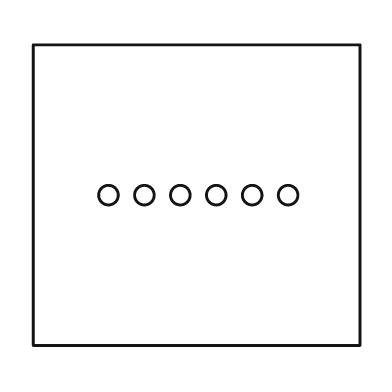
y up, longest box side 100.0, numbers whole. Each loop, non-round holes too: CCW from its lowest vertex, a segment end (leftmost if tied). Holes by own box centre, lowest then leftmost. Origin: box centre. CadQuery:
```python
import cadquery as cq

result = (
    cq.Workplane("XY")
    .moveTo(-50.0, -46.0)
    .lineTo(50.0, -46.0)
    .lineTo(50.0, 46.0)
    .lineTo(-50.0, 46.0)
    .close()
    .moveTo(-27.0, 0.0)
    .circle(3.0)
    .moveTo(-16.0, 0.0)
    .circle(3.0)
    .moveTo(-5.0, 0.0)
    .circle(3.0)
    .moveTo(6.0, 0.0)
    .circle(3.0)
    .moveTo(17.0, 0.0)
    .circle(3.0)
    .moveTo(28.0, 0.0)
    .circle(3.0)
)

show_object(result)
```